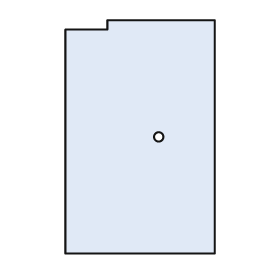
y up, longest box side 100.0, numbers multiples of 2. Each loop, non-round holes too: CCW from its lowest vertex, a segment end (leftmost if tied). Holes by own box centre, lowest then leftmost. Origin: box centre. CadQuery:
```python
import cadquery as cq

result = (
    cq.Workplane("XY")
    .moveTo(-32.0, -50.0)
    .lineTo(32.0, -50.0)
    .lineTo(32.0, 50.0)
    .lineTo(-14.0, 50.0)
    .lineTo(-14.0, 46.0)
    .lineTo(-32.0, 46.0)
    .close()
    .moveTo(8.0, 0.0)
    .circle(2.0)
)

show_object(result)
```